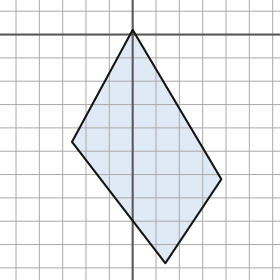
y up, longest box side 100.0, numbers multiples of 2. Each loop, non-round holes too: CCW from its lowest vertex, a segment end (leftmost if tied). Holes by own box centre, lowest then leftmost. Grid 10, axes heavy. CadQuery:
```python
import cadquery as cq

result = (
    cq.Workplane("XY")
    .moveTo(14.0, -98.0)
    .lineTo(38.0, -62.0)
    .lineTo(0.0, 2.0)
    .lineTo(-26.0, -46.0)
    .close()
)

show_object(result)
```